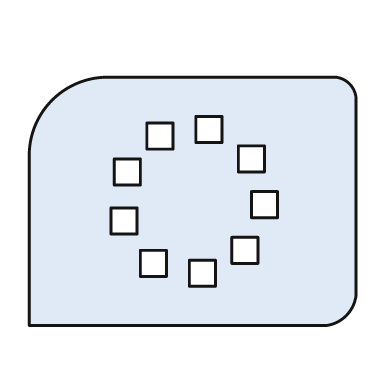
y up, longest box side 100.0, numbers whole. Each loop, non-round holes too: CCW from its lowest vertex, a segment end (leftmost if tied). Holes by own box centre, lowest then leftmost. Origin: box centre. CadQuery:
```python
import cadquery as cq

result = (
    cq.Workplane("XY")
    .moveTo(-50.0, -38.0)
    .lineTo(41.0, -38.0)
    .threePointArc((47.0, -35.0), (50.0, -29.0))
    .lineTo(50.0, 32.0)
    .threePointArc((48.0, 36.0), (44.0, 38.0))
    .lineTo(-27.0, 38.0)
    .threePointArc((-43.0, 31.0), (-50.0, 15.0))
    .close()
    .moveTo(-1.0, -26.0)
    .lineTo(7.0, -26.0)
    .lineTo(7.0, -18.0)
    .lineTo(-1.0, -18.0)
    .close()
    .moveTo(-16.0, -23.0)
    .lineTo(-8.0, -23.0)
    .lineTo(-8.0, -15.0)
    .lineTo(-16.0, -15.0)
    .close()
    .moveTo(12.0, -19.0)
    .lineTo(20.0, -19.0)
    .lineTo(20.0, -11.0)
    .lineTo(12.0, -11.0)
    .close()
    .moveTo(-25.0, -10.0)
    .lineTo(-17.0, -10.0)
    .lineTo(-17.0, -2.0)
    .lineTo(-25.0, -2.0)
    .close()
    .moveTo(18.0, -5.0)
    .lineTo(26.0, -5.0)
    .lineTo(26.0, 3.0)
    .lineTo(18.0, 3.0)
    .close()
    .moveTo(-24.0, 5.0)
    .lineTo(-16.0, 5.0)
    .lineTo(-16.0, 13.0)
    .lineTo(-24.0, 13.0)
    .close()
    .moveTo(14.0, 9.0)
    .lineTo(22.0, 9.0)
    .lineTo(22.0, 17.0)
    .lineTo(14.0, 17.0)
    .close()
    .moveTo(-14.0, 16.0)
    .lineTo(-6.0, 16.0)
    .lineTo(-6.0, 24.0)
    .lineTo(-14.0, 24.0)
    .close()
    .moveTo(1.0, 18.0)
    .lineTo(9.0, 18.0)
    .lineTo(9.0, 26.0)
    .lineTo(1.0, 26.0)
    .close()
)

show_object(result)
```